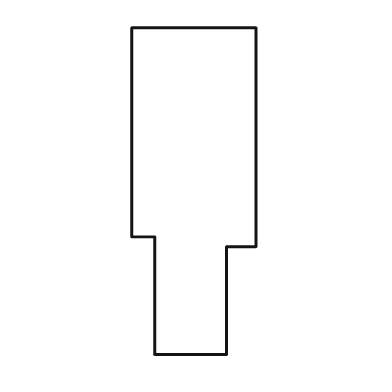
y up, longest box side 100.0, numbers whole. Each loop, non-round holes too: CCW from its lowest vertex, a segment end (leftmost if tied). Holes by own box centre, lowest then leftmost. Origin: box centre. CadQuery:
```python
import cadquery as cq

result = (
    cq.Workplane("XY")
    .moveTo(-12.0, -50.0)
    .lineTo(10.0, -50.0)
    .lineTo(10.0, -17.0)
    .lineTo(19.0, -17.0)
    .lineTo(19.0, 50.0)
    .lineTo(-19.0, 50.0)
    .lineTo(-19.0, -14.0)
    .lineTo(-12.0, -14.0)
    .close()
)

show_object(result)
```